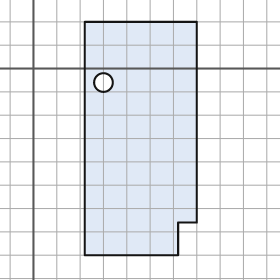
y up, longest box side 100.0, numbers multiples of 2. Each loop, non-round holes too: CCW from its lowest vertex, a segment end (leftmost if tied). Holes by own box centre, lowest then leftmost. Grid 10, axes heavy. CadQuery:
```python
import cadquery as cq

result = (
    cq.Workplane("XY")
    .moveTo(22.0, -80.0)
    .lineTo(62.0, -80.0)
    .lineTo(62.0, -66.0)
    .lineTo(70.0, -66.0)
    .lineTo(70.0, 20.0)
    .lineTo(22.0, 20.0)
    .close()
    .moveTo(30.0, -6.0)
    .circle(4.0)
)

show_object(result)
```